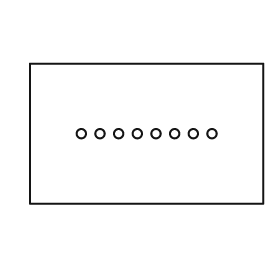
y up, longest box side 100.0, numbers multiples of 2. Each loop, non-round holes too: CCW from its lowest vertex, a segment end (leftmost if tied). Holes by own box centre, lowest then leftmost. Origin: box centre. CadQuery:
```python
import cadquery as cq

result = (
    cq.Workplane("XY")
    .moveTo(-50.0, -30.0)
    .lineTo(50.0, -30.0)
    .lineTo(50.0, 30.0)
    .lineTo(-50.0, 30.0)
    .close()
    .moveTo(-28.0, 0.0)
    .circle(2.0)
    .moveTo(-20.0, 0.0)
    .circle(2.0)
    .moveTo(-12.0, 0.0)
    .circle(2.0)
    .moveTo(-4.0, 0.0)
    .circle(2.0)
    .moveTo(4.0, 0.0)
    .circle(2.0)
    .moveTo(12.0, 0.0)
    .circle(2.0)
    .moveTo(20.0, 0.0)
    .circle(2.0)
    .moveTo(28.0, 0.0)
    .circle(2.0)
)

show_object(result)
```